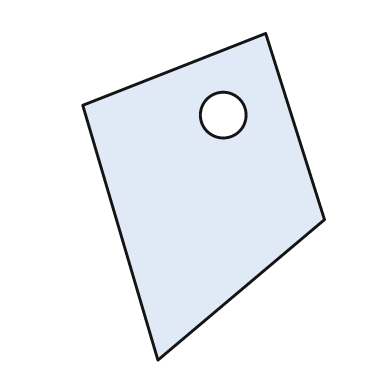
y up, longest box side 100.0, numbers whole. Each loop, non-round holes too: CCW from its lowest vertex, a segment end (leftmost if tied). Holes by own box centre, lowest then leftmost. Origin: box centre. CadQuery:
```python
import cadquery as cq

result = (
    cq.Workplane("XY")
    .moveTo(-14.0, -50.0)
    .lineTo(37.0, -7.0)
    .lineTo(19.0, 50.0)
    .lineTo(-37.0, 28.0)
    .close()
    .moveTo(6.0, 25.0)
    .circle(7.0)
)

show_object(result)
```